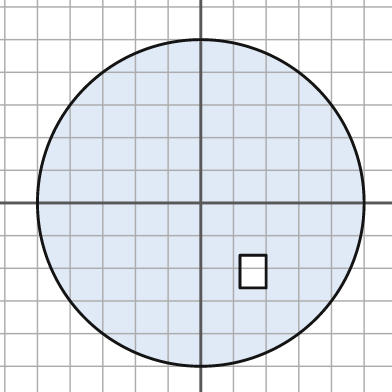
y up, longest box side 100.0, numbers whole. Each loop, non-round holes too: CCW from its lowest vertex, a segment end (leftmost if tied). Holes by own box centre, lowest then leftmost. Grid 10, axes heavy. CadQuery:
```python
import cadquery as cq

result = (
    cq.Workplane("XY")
    .moveTo(0.0, 0.0)
    .circle(50.0)
    .moveTo(12.0, -26.0)
    .lineTo(20.0, -26.0)
    .lineTo(20.0, -16.0)
    .lineTo(12.0, -16.0)
    .close()
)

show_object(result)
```